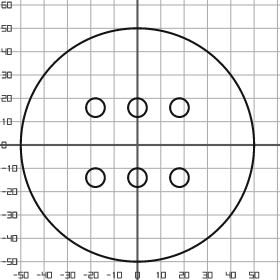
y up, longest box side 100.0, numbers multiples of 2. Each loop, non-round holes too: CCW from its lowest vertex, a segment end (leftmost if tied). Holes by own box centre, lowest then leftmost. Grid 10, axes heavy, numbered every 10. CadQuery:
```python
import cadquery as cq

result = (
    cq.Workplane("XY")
    .moveTo(0.0, 0.0)
    .circle(50.0)
    .moveTo(-18.0, -14.0)
    .circle(4.0)
    .moveTo(0.0, -14.0)
    .circle(4.0)
    .moveTo(18.0, -14.0)
    .circle(4.0)
    .moveTo(-18.0, 16.0)
    .circle(4.0)
    .moveTo(0.0, 16.0)
    .circle(4.0)
    .moveTo(18.0, 16.0)
    .circle(4.0)
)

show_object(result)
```